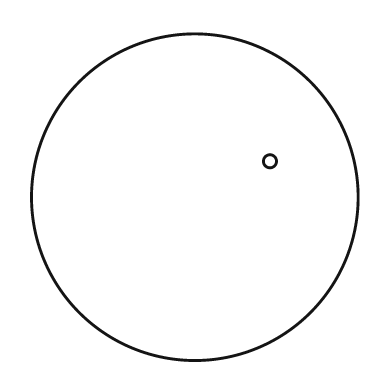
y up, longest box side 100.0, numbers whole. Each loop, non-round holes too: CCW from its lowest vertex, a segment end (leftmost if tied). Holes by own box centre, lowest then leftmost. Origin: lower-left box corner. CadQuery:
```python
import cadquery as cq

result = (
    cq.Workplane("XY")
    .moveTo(50.0, 50.0)
    .circle(50.0)
    .moveTo(73.0, 61.0)
    .circle(2.0)
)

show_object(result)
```